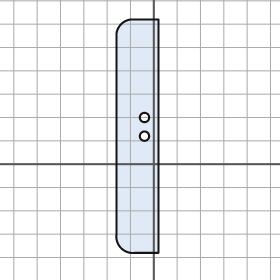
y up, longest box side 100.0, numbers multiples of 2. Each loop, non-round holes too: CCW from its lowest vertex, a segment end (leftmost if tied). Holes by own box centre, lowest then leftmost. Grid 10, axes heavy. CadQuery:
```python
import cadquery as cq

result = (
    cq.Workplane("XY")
    .moveTo(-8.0, -38.0)
    .lineTo(2.0, -38.0)
    .lineTo(2.0, 62.0)
    .lineTo(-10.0, 62.0)
    .threePointArc((-14.0, 60.0), (-16.0, 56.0))
    .lineTo(-16.0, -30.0)
    .threePointArc((-14.0, -36.0), (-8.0, -38.0))
    .close()
    .moveTo(-4.0, 12.0)
    .circle(2.0)
    .moveTo(-4.0, 20.0)
    .circle(2.0)
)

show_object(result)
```